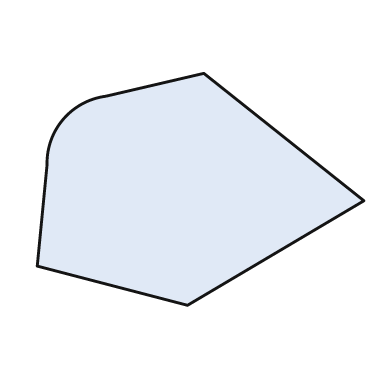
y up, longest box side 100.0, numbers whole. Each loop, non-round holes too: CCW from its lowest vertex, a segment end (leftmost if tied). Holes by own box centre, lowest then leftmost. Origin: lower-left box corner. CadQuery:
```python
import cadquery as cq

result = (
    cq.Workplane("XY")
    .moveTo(46.0, 0.0)
    .lineTo(100.0, 32.0)
    .lineTo(51.0, 71.0)
    .lineTo(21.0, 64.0)
    .threePointArc((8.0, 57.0), (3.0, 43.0))
    .lineTo(0.0, 12.0)
    .close()
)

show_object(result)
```